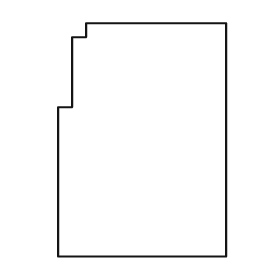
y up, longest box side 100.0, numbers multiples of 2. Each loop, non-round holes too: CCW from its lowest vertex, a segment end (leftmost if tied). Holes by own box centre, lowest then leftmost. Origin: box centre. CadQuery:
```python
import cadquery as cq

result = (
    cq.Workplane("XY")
    .moveTo(-36.0, -50.0)
    .lineTo(36.0, -50.0)
    .lineTo(36.0, 50.0)
    .lineTo(-24.0, 50.0)
    .lineTo(-24.0, 44.0)
    .lineTo(-30.0, 44.0)
    .lineTo(-30.0, 14.0)
    .lineTo(-36.0, 14.0)
    .close()
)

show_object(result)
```